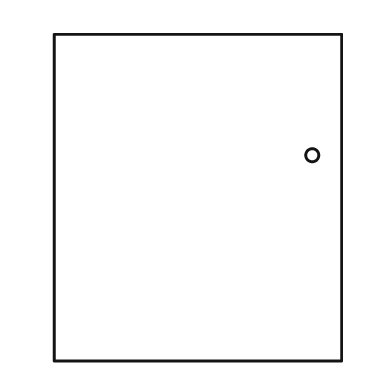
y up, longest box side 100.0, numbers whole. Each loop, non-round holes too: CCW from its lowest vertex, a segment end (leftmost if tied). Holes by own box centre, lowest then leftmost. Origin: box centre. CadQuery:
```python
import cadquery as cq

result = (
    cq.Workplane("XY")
    .moveTo(-44.0, -50.0)
    .lineTo(44.0, -50.0)
    .lineTo(44.0, 50.0)
    .lineTo(-44.0, 50.0)
    .close()
    .moveTo(35.0, 13.0)
    .circle(2.0)
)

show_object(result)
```